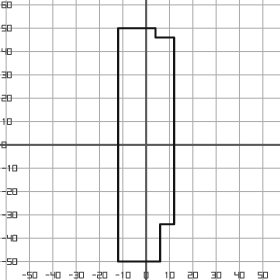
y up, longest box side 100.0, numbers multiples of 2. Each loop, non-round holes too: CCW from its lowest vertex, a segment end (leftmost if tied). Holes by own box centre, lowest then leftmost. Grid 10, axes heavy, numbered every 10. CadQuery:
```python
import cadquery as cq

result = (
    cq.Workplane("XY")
    .moveTo(-12.0, -50.0)
    .lineTo(6.0, -50.0)
    .lineTo(6.0, -34.0)
    .lineTo(12.0, -34.0)
    .lineTo(12.0, 46.0)
    .lineTo(4.0, 46.0)
    .lineTo(4.0, 50.0)
    .lineTo(-12.0, 50.0)
    .close()
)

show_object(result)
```